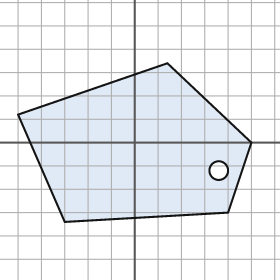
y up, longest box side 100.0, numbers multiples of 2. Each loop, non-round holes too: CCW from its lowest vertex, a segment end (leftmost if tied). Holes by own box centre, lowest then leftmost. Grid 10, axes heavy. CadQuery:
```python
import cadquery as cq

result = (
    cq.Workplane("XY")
    .moveTo(-30.0, -34.0)
    .lineTo(40.0, -30.0)
    .lineTo(50.0, 0.0)
    .lineTo(14.0, 34.0)
    .lineTo(-50.0, 12.0)
    .close()
    .moveTo(36.0, -12.0)
    .circle(4.0)
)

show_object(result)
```